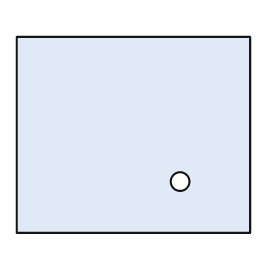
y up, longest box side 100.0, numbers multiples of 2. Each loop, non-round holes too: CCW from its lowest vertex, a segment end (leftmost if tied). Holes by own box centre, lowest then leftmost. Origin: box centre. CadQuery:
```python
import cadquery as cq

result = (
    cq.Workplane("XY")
    .moveTo(-50.0, -42.0)
    .lineTo(50.0, -42.0)
    .lineTo(50.0, 42.0)
    .lineTo(-50.0, 42.0)
    .close()
    .moveTo(20.0, -20.0)
    .circle(4.0)
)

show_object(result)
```